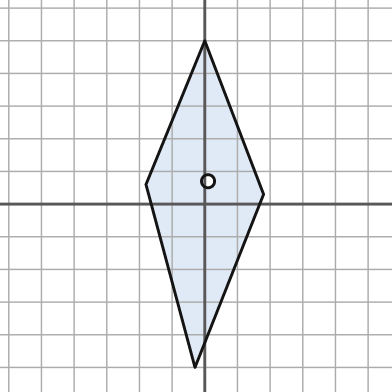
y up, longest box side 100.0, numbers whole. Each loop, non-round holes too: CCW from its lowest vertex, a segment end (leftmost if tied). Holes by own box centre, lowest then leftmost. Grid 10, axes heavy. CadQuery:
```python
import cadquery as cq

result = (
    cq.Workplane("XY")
    .moveTo(-3.0, -50.0)
    .lineTo(18.0, 3.0)
    .lineTo(0.0, 50.0)
    .lineTo(-18.0, 6.0)
    .close()
    .moveTo(1.0, 7.0)
    .circle(2.0)
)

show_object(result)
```